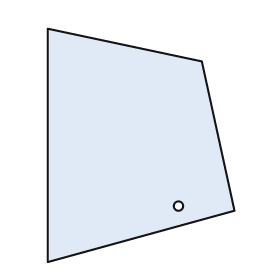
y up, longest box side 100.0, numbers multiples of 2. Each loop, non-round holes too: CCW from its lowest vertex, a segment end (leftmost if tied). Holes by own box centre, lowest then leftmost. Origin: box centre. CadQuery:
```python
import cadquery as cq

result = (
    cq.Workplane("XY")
    .moveTo(-40.0, -50.0)
    .lineTo(40.0, -28.0)
    .lineTo(26.0, 36.0)
    .lineTo(-40.0, 50.0)
    .close()
    .moveTo(16.0, -26.0)
    .circle(2.0)
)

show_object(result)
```